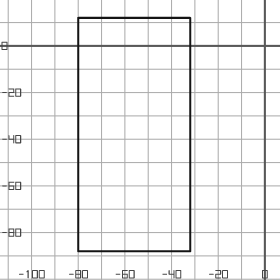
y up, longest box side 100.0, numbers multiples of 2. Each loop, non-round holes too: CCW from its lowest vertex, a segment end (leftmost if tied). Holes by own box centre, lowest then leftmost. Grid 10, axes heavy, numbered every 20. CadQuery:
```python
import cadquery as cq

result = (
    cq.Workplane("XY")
    .moveTo(-80.0, -88.0)
    .lineTo(-32.0, -88.0)
    .lineTo(-32.0, 12.0)
    .lineTo(-80.0, 12.0)
    .close()
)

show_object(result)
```